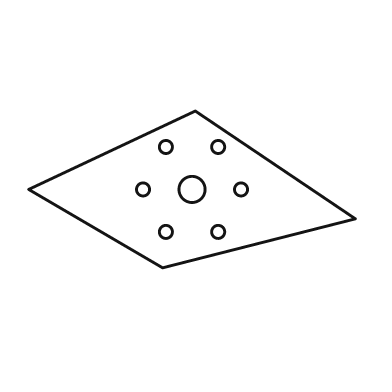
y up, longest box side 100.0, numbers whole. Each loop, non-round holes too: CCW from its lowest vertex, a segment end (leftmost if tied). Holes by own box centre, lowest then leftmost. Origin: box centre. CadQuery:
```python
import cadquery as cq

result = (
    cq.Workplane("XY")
    .moveTo(-9.0, -24.0)
    .lineTo(50.0, -9.0)
    .lineTo(1.0, 24.0)
    .lineTo(-50.0, 0.0)
    .close()
    .moveTo(-8.0, -13.0)
    .circle(2.0)
    .moveTo(8.0, -13.0)
    .circle(2.0)
    .moveTo(-15.0, 0.0)
    .circle(2.0)
    .moveTo(0.0, 0.0)
    .circle(4.0)
    .moveTo(15.0, 0.0)
    .circle(2.0)
    .moveTo(-8.0, 13.0)
    .circle(2.0)
    .moveTo(8.0, 13.0)
    .circle(2.0)
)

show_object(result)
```